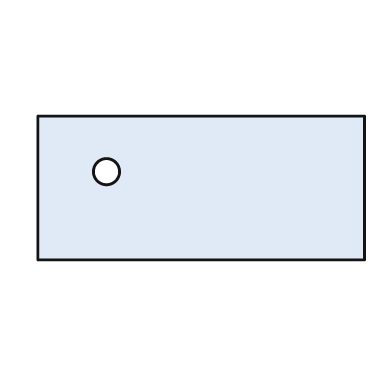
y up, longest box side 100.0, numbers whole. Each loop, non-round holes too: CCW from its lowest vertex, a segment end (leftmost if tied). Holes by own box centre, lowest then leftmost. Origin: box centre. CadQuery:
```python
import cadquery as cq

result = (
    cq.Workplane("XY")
    .moveTo(-50.0, -22.0)
    .lineTo(50.0, -22.0)
    .lineTo(50.0, 22.0)
    .lineTo(-50.0, 22.0)
    .close()
    .moveTo(-29.0, 5.0)
    .circle(4.0)
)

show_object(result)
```